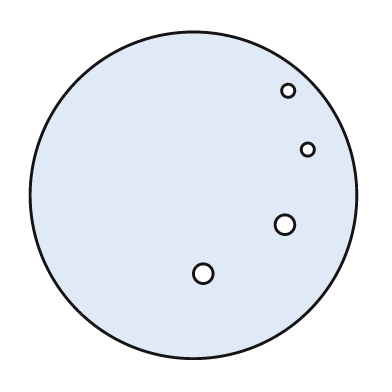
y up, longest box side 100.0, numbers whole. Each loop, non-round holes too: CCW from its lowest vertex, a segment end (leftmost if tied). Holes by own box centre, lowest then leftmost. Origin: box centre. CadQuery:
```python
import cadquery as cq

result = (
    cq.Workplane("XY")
    .moveTo(0.0, 0.0)
    .circle(50.0)
    .moveTo(3.0, -24.0)
    .circle(3.0)
    .moveTo(28.0, -9.0)
    .circle(3.0)
    .moveTo(35.0, 14.0)
    .circle(2.0)
    .moveTo(29.0, 32.0)
    .circle(2.0)
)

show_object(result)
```